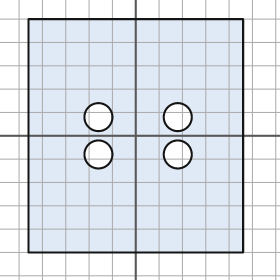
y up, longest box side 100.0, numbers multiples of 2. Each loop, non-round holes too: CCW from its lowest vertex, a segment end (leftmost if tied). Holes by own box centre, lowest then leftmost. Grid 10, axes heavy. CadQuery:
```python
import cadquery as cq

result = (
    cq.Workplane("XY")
    .moveTo(-46.0, -50.0)
    .lineTo(46.0, -50.0)
    .lineTo(46.0, 50.0)
    .lineTo(-46.0, 50.0)
    .close()
    .moveTo(-16.0, -8.0)
    .circle(6.0)
    .moveTo(18.0, -8.0)
    .circle(6.0)
    .moveTo(-16.0, 8.0)
    .circle(6.0)
    .moveTo(18.0, 8.0)
    .circle(6.0)
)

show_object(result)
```